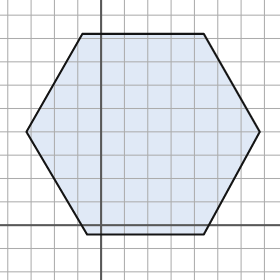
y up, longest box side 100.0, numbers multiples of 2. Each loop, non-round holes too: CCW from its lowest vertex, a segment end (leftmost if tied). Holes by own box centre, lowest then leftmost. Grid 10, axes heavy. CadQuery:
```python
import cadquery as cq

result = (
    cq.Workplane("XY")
    .moveTo(-6.0, -4.0)
    .lineTo(44.0, -4.0)
    .lineTo(68.0, 40.0)
    .lineTo(44.0, 82.0)
    .lineTo(-8.0, 82.0)
    .lineTo(-32.0, 40.0)
    .close()
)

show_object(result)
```